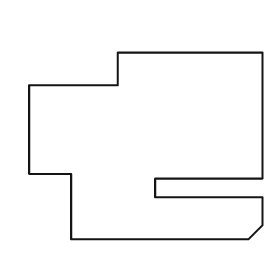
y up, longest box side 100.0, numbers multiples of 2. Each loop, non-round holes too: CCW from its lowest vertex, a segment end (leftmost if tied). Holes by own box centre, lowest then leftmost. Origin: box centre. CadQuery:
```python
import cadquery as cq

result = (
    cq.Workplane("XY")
    .moveTo(-32.0, -40.0)
    .lineTo(44.0, -40.0)
    .lineTo(50.0, -34.0)
    .lineTo(50.0, -22.0)
    .lineTo(4.0, -22.0)
    .lineTo(4.0, -14.0)
    .lineTo(50.0, -14.0)
    .lineTo(50.0, 40.0)
    .lineTo(-12.0, 40.0)
    .lineTo(-12.0, 26.0)
    .lineTo(-50.0, 26.0)
    .lineTo(-50.0, -12.0)
    .lineTo(-32.0, -12.0)
    .close()
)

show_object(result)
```